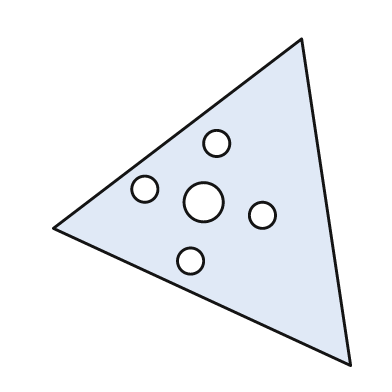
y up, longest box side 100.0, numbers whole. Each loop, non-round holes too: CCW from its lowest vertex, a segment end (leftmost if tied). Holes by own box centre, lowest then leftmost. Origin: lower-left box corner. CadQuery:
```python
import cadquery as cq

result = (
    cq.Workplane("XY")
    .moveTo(91.0, 0.0)
    .lineTo(76.0, 100.0)
    .lineTo(0.0, 42.0)
    .close()
    .moveTo(42.0, 32.0)
    .circle(4.0)
    .moveTo(64.0, 46.0)
    .circle(4.0)
    .moveTo(46.0, 50.0)
    .circle(6.0)
    .moveTo(28.0, 54.0)
    .circle(4.0)
    .moveTo(50.0, 68.0)
    .circle(4.0)
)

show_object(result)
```